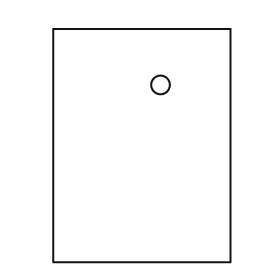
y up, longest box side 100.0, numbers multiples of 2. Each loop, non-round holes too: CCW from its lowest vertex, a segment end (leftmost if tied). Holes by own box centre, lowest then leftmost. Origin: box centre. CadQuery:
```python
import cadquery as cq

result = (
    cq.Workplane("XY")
    .moveTo(-38.0, -50.0)
    .lineTo(38.0, -50.0)
    .lineTo(38.0, 50.0)
    .lineTo(-38.0, 50.0)
    .close()
    .moveTo(8.0, 26.0)
    .circle(4.0)
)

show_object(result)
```